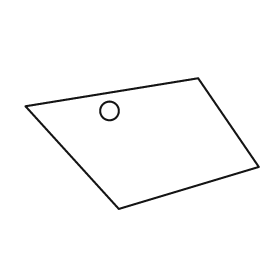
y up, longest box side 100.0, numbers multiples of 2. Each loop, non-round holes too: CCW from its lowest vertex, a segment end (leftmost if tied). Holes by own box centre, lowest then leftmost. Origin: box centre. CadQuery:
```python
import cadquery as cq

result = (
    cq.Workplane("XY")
    .moveTo(-10.0, -28.0)
    .lineTo(50.0, -10.0)
    .lineTo(24.0, 28.0)
    .lineTo(-50.0, 16.0)
    .close()
    .moveTo(-14.0, 14.0)
    .circle(4.0)
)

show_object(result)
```